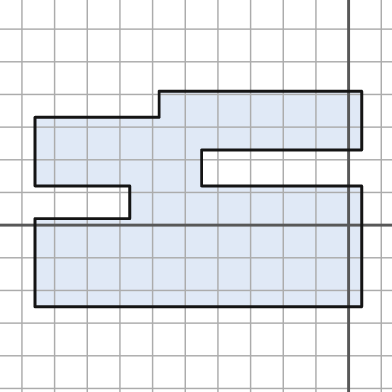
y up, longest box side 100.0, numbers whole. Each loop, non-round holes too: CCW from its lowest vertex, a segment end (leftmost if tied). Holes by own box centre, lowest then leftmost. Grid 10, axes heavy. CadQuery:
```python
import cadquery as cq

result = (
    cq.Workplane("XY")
    .moveTo(-96.0, -25.0)
    .lineTo(4.0, -25.0)
    .lineTo(4.0, 12.0)
    .lineTo(-45.0, 12.0)
    .lineTo(-45.0, 23.0)
    .lineTo(4.0, 23.0)
    .lineTo(4.0, 41.0)
    .lineTo(-58.0, 41.0)
    .lineTo(-58.0, 33.0)
    .lineTo(-96.0, 33.0)
    .lineTo(-96.0, 12.0)
    .lineTo(-67.0, 12.0)
    .lineTo(-67.0, 2.0)
    .lineTo(-96.0, 2.0)
    .close()
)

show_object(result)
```